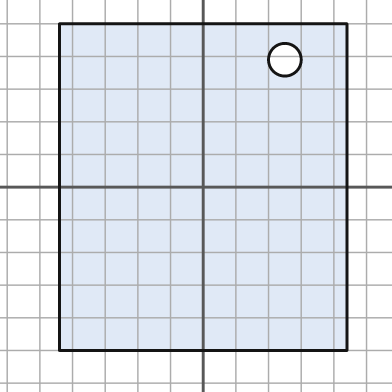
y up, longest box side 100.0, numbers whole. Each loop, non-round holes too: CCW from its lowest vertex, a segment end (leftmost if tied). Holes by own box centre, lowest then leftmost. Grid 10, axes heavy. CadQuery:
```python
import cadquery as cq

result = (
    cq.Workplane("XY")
    .moveTo(-44.0, -50.0)
    .lineTo(44.0, -50.0)
    .lineTo(44.0, 50.0)
    .lineTo(-44.0, 50.0)
    .close()
    .moveTo(25.0, 39.0)
    .circle(5.0)
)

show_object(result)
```